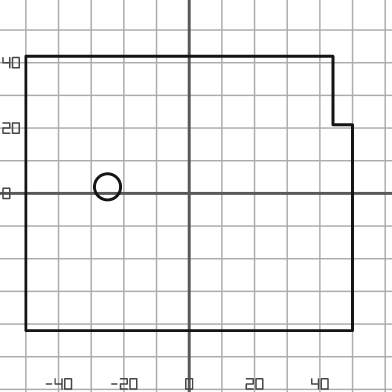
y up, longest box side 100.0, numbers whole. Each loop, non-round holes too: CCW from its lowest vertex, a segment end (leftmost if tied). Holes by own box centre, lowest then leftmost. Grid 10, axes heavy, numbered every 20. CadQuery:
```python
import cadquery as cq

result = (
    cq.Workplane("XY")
    .moveTo(-50.0, -42.0)
    .lineTo(50.0, -42.0)
    .lineTo(50.0, 21.0)
    .lineTo(44.0, 21.0)
    .lineTo(44.0, 42.0)
    .lineTo(-50.0, 42.0)
    .close()
    .moveTo(-25.0, 2.0)
    .circle(4.0)
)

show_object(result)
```